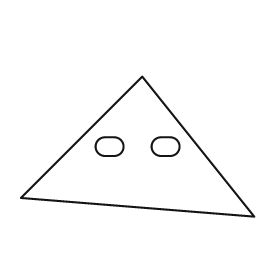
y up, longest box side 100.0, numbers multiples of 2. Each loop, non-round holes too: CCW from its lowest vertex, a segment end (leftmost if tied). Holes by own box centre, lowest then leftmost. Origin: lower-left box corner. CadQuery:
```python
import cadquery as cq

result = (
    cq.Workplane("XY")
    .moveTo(100.0, 0.0)
    .lineTo(52.0, 60.0)
    .lineTo(0.0, 8.0)
    .close()
    .moveTo(36.0, 26.0)
    .lineTo(40.0, 26.0)
    .threePointArc((44.0, 30.0), (40.0, 34.0))
    .lineTo(36.0, 34.0)
    .threePointArc((32.0, 30.0), (36.0, 26.0))
    .close()
    .moveTo(60.0, 26.0)
    .lineTo(64.0, 26.0)
    .threePointArc((68.0, 30.0), (64.0, 34.0))
    .lineTo(60.0, 34.0)
    .threePointArc((56.0, 30.0), (60.0, 26.0))
    .close()
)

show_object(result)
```